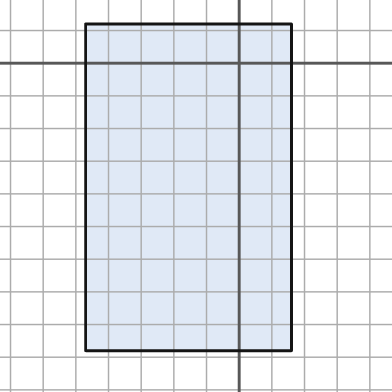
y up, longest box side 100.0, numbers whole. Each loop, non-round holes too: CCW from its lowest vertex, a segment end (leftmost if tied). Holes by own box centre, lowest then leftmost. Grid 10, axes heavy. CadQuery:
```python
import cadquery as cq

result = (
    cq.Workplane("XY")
    .moveTo(-47.0, -88.0)
    .lineTo(16.0, -88.0)
    .lineTo(16.0, 12.0)
    .lineTo(-47.0, 12.0)
    .close()
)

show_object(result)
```